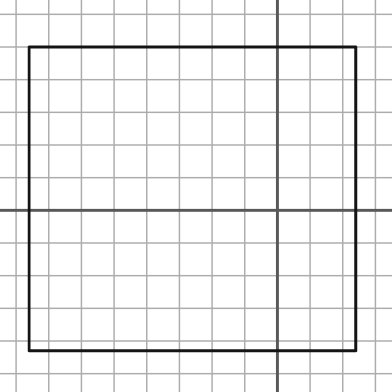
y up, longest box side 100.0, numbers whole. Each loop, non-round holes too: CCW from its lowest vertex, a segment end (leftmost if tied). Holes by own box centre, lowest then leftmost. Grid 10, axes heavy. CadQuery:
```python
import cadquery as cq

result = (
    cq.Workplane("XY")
    .moveTo(-76.0, -43.0)
    .lineTo(24.0, -43.0)
    .lineTo(24.0, 50.0)
    .lineTo(-76.0, 50.0)
    .close()
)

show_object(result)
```